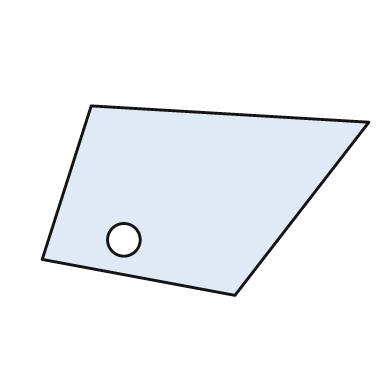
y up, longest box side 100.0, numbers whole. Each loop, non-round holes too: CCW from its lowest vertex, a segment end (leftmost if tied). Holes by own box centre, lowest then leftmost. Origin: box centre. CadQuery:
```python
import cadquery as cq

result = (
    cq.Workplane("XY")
    .moveTo(9.0, -29.0)
    .lineTo(50.0, 24.0)
    .lineTo(-35.0, 29.0)
    .lineTo(-50.0, -18.0)
    .close()
    .moveTo(-25.0, -12.0)
    .circle(5.0)
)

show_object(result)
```